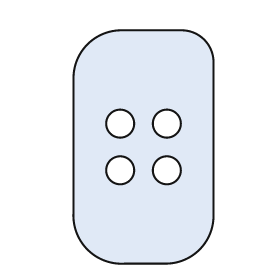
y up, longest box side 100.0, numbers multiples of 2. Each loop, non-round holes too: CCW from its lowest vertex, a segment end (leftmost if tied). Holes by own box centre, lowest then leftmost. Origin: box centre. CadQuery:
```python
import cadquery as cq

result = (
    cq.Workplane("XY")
    .moveTo(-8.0, -50.0)
    .lineTo(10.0, -50.0)
    .threePointArc((24.0, -44.0), (30.0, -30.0))
    .lineTo(30.0, 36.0)
    .threePointArc((26.0, 46.0), (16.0, 50.0))
    .lineTo(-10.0, 50.0)
    .threePointArc((-24.0, 44.0), (-30.0, 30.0))
    .lineTo(-30.0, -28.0)
    .threePointArc((-24.0, -44.0), (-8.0, -50.0))
    .close()
    .moveTo(-10.0, -10.0)
    .circle(6.0)
    .moveTo(10.0, -10.0)
    .circle(6.0)
    .moveTo(-10.0, 10.0)
    .circle(6.0)
    .moveTo(10.0, 10.0)
    .circle(6.0)
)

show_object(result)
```